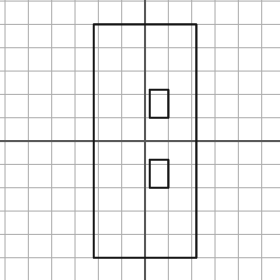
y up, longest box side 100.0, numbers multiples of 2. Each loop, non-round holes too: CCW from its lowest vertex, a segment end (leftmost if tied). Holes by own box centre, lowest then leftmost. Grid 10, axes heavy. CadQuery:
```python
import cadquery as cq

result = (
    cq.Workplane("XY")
    .moveTo(-22.0, -50.0)
    .lineTo(22.0, -50.0)
    .lineTo(22.0, 50.0)
    .lineTo(-22.0, 50.0)
    .close()
    .moveTo(2.0, -20.0)
    .lineTo(10.0, -20.0)
    .lineTo(10.0, -8.0)
    .lineTo(2.0, -8.0)
    .close()
    .moveTo(2.0, 10.0)
    .lineTo(10.0, 10.0)
    .lineTo(10.0, 22.0)
    .lineTo(2.0, 22.0)
    .close()
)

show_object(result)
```